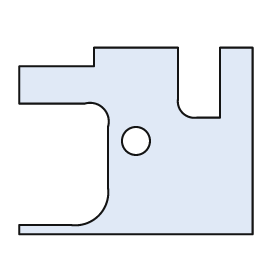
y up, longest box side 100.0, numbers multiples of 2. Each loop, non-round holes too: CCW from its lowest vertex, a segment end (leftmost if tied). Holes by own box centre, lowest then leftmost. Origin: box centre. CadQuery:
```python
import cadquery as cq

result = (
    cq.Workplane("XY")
    .moveTo(-50.0, -40.0)
    .lineTo(50.0, -40.0)
    .lineTo(50.0, 40.0)
    .lineTo(36.0, 40.0)
    .lineTo(36.0, 10.0)
    .lineTo(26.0, 10.0)
    .threePointArc((20.0, 12.0), (18.0, 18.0))
    .lineTo(18.0, 40.0)
    .lineTo(-18.0, 40.0)
    .lineTo(-18.0, 32.0)
    .lineTo(-50.0, 32.0)
    .lineTo(-50.0, 16.0)
    .lineTo(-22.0, 16.0)
    .threePointArc((-14.0, 14.0), (-12.0, 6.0))
    .lineTo(-12.0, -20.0)
    .threePointArc((-16.0, -32.0), (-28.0, -36.0))
    .lineTo(-50.0, -36.0)
    .close()
    .moveTo(0.0, 0.0)
    .circle(6.0)
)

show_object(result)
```